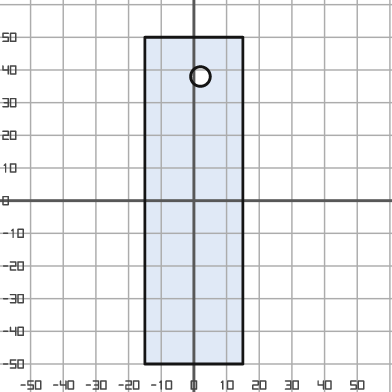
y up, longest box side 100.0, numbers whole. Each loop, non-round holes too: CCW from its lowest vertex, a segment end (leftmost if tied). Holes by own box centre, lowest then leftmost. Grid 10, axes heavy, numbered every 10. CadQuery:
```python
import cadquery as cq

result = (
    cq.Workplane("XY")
    .moveTo(-15.0, -50.0)
    .lineTo(15.0, -50.0)
    .lineTo(15.0, 50.0)
    .lineTo(-15.0, 50.0)
    .close()
    .moveTo(2.0, 38.0)
    .circle(3.0)
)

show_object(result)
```